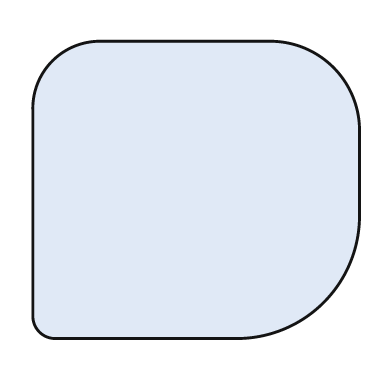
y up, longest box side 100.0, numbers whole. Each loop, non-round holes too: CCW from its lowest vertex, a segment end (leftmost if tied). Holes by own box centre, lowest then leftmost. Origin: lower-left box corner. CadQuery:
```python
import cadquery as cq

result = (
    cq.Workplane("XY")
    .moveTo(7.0, 0.0)
    .lineTo(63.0, 0.0)
    .threePointArc((89.0, 11.0), (100.0, 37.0))
    .lineTo(100.0, 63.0)
    .threePointArc((92.0, 83.0), (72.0, 91.0))
    .lineTo(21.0, 91.0)
    .threePointArc((6.0, 85.0), (0.0, 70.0))
    .lineTo(0.0, 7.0)
    .threePointArc((2.0, 2.0), (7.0, 0.0))
    .close()
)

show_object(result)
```